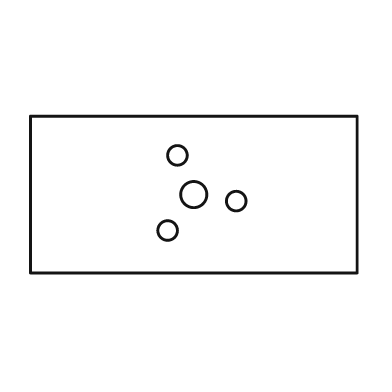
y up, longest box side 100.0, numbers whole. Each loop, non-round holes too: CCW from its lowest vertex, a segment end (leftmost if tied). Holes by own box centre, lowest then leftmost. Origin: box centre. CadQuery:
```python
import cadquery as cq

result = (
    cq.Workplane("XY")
    .moveTo(-50.0, -24.0)
    .lineTo(50.0, -24.0)
    .lineTo(50.0, 24.0)
    .lineTo(-50.0, 24.0)
    .close()
    .moveTo(-8.0, -11.0)
    .circle(3.0)
    .moveTo(13.0, -2.0)
    .circle(3.0)
    .moveTo(0.0, 0.0)
    .circle(4.0)
    .moveTo(-5.0, 12.0)
    .circle(3.0)
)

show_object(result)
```